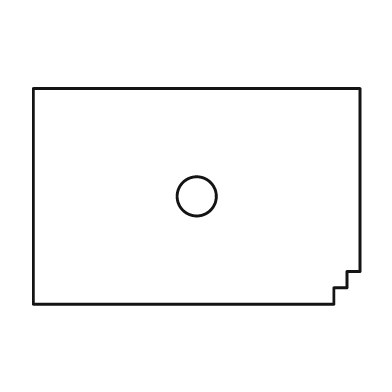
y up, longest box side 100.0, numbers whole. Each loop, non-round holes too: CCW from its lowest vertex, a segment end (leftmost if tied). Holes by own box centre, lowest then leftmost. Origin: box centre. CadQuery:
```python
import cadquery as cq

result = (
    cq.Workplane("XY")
    .moveTo(-50.0, -33.0)
    .lineTo(42.0, -33.0)
    .lineTo(42.0, -28.0)
    .lineTo(46.0, -28.0)
    .lineTo(46.0, -23.0)
    .lineTo(50.0, -23.0)
    .lineTo(50.0, 33.0)
    .lineTo(-50.0, 33.0)
    .close()
    .moveTo(0.0, 0.0)
    .circle(6.0)
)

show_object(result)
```